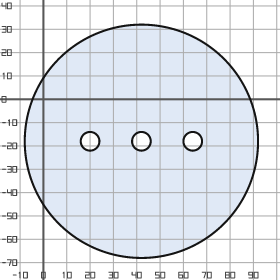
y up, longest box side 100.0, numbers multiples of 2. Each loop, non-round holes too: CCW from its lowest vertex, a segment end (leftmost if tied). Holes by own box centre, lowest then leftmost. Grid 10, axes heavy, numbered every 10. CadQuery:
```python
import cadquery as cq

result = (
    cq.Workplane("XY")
    .moveTo(42.0, -18.0)
    .circle(50.0)
    .moveTo(20.0, -18.0)
    .circle(4.0)
    .moveTo(42.0, -18.0)
    .circle(4.0)
    .moveTo(64.0, -18.0)
    .circle(4.0)
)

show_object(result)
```